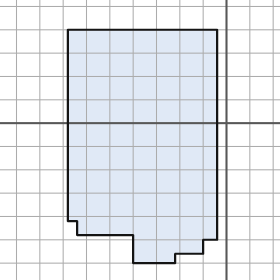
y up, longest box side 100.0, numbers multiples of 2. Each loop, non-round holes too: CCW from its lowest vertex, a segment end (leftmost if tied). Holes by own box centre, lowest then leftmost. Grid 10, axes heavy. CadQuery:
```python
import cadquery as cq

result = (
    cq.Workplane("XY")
    .moveTo(-40.0, -60.0)
    .lineTo(-22.0, -60.0)
    .lineTo(-22.0, -56.0)
    .lineTo(-10.0, -56.0)
    .lineTo(-10.0, -50.0)
    .lineTo(-4.0, -50.0)
    .lineTo(-4.0, 40.0)
    .lineTo(-68.0, 40.0)
    .lineTo(-68.0, -42.0)
    .lineTo(-64.0, -42.0)
    .lineTo(-64.0, -48.0)
    .lineTo(-40.0, -48.0)
    .close()
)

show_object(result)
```